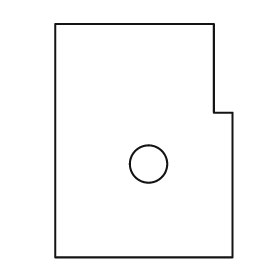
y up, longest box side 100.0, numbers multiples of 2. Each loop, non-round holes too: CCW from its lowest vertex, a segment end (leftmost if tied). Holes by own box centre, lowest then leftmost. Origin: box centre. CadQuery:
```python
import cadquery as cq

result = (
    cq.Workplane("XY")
    .moveTo(-38.0, -50.0)
    .lineTo(38.0, -50.0)
    .lineTo(38.0, 12.0)
    .lineTo(30.0, 12.0)
    .lineTo(30.0, 50.0)
    .lineTo(-38.0, 50.0)
    .close()
    .moveTo(2.0, -10.0)
    .circle(8.0)
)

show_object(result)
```